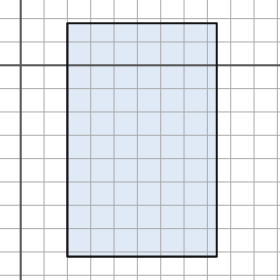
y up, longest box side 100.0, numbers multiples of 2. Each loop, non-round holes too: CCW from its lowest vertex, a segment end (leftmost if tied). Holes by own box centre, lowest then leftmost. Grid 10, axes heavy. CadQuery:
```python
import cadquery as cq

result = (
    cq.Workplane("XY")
    .moveTo(20.0, -82.0)
    .lineTo(84.0, -82.0)
    .lineTo(84.0, 18.0)
    .lineTo(20.0, 18.0)
    .close()
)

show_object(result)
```